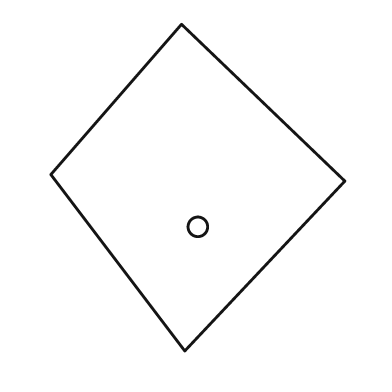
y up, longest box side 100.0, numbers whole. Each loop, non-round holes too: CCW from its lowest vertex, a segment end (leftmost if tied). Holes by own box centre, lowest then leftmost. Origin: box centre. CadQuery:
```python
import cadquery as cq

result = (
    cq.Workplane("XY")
    .moveTo(-4.0, -50.0)
    .lineTo(45.0, 2.0)
    .lineTo(-5.0, 50.0)
    .lineTo(-45.0, 4.0)
    .close()
    .moveTo(0.0, -12.0)
    .circle(3.0)
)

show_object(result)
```